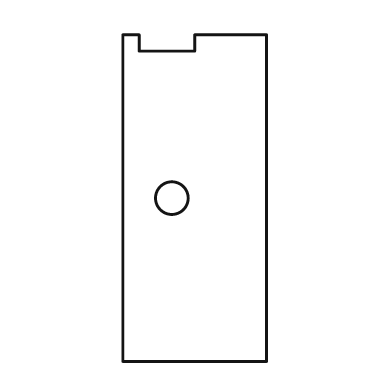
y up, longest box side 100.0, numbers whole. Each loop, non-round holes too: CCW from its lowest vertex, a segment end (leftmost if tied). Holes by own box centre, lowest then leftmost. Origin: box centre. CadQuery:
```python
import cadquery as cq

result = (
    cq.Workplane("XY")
    .moveTo(-22.0, -50.0)
    .lineTo(22.0, -50.0)
    .lineTo(22.0, 50.0)
    .lineTo(0.0, 50.0)
    .lineTo(0.0, 45.0)
    .lineTo(-17.0, 45.0)
    .lineTo(-17.0, 50.0)
    .lineTo(-22.0, 50.0)
    .close()
    .moveTo(-7.0, 0.0)
    .circle(5.0)
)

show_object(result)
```